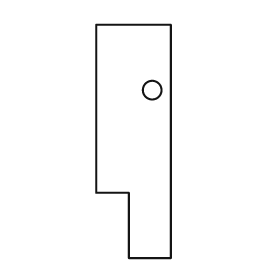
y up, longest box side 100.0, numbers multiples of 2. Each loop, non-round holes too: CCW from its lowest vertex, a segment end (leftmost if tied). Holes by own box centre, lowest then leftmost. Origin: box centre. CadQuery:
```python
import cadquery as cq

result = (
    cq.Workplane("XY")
    .moveTo(-2.0, -50.0)
    .lineTo(16.0, -50.0)
    .lineTo(16.0, 50.0)
    .lineTo(-16.0, 50.0)
    .lineTo(-16.0, -22.0)
    .lineTo(-2.0, -22.0)
    .close()
    .moveTo(8.0, 22.0)
    .circle(4.0)
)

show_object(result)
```